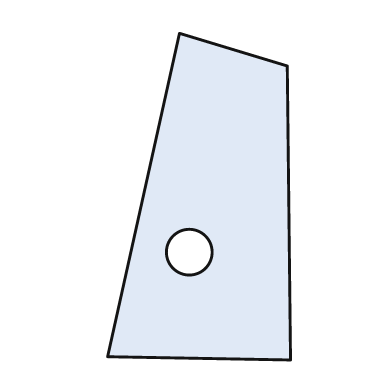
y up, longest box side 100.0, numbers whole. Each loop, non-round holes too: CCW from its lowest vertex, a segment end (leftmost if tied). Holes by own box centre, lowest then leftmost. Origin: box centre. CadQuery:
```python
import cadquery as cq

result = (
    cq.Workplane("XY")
    .moveTo(28.0, -50.0)
    .lineTo(27.0, 40.0)
    .lineTo(-6.0, 50.0)
    .lineTo(-28.0, -49.0)
    .close()
    .moveTo(-3.0, -17.0)
    .circle(7.0)
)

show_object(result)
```